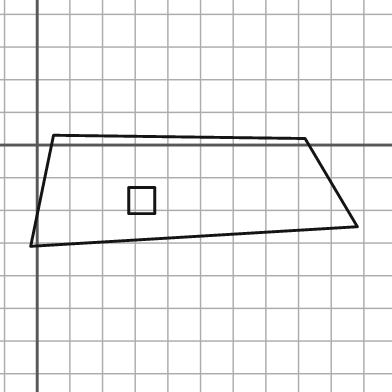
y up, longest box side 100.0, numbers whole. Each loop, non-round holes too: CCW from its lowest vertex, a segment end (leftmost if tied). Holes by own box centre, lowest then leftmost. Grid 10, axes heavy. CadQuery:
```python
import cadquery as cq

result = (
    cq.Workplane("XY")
    .moveTo(-2.0, -31.0)
    .lineTo(98.0, -25.0)
    .lineTo(82.0, 2.0)
    .lineTo(5.0, 3.0)
    .close()
    .moveTo(28.0, -21.0)
    .lineTo(36.0, -21.0)
    .lineTo(36.0, -13.0)
    .lineTo(28.0, -13.0)
    .close()
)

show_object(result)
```